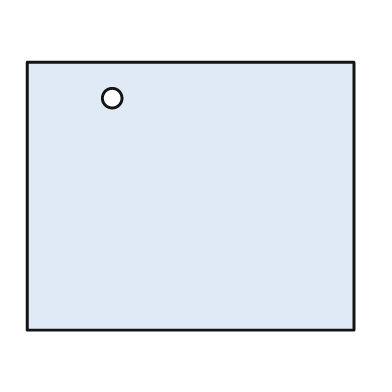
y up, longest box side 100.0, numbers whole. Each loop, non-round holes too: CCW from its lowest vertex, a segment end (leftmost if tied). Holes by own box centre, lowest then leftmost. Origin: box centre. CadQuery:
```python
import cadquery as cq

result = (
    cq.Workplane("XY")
    .moveTo(-50.0, -41.0)
    .lineTo(50.0, -41.0)
    .lineTo(50.0, 41.0)
    .lineTo(-50.0, 41.0)
    .close()
    .moveTo(-24.0, 30.0)
    .circle(3.0)
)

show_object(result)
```